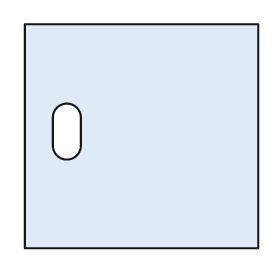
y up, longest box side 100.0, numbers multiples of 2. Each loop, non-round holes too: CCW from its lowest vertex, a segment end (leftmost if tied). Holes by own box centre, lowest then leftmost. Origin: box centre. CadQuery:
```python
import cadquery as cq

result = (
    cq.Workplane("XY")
    .moveTo(-50.0, -48.0)
    .lineTo(50.0, -48.0)
    .lineTo(50.0, 48.0)
    .lineTo(-50.0, 48.0)
    .close()
    .moveTo(-38.0, -4.0)
    .threePointArc((-32.0, -10.0), (-26.0, -4.0))
    .lineTo(-26.0, 8.0)
    .threePointArc((-32.0, 14.0), (-38.0, 8.0))
    .close()
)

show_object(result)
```